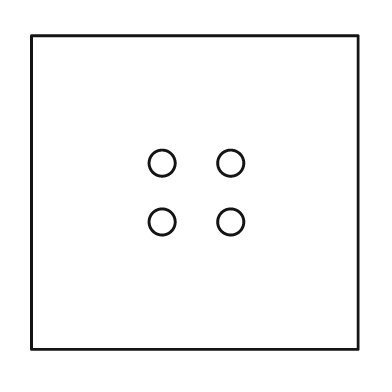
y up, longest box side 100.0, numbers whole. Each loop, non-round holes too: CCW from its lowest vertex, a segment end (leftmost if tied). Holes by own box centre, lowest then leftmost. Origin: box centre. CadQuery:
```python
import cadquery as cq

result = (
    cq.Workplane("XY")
    .moveTo(-50.0, -48.0)
    .lineTo(50.0, -48.0)
    .lineTo(50.0, 48.0)
    .lineTo(-50.0, 48.0)
    .close()
    .moveTo(-10.0, -9.0)
    .circle(4.0)
    .moveTo(11.0, -9.0)
    .circle(4.0)
    .moveTo(-10.0, 9.0)
    .circle(4.0)
    .moveTo(11.0, 9.0)
    .circle(4.0)
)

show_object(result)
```